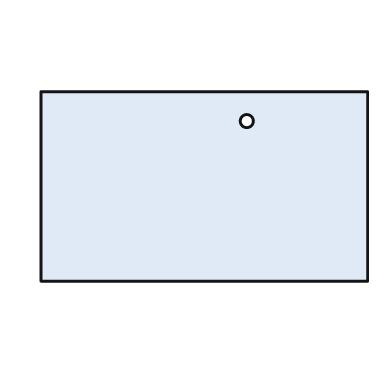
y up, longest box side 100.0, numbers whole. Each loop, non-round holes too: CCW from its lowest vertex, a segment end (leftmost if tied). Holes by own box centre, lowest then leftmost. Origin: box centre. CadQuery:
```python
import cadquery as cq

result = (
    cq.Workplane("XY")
    .moveTo(-50.0, -29.0)
    .lineTo(50.0, -29.0)
    .lineTo(50.0, 29.0)
    .lineTo(-50.0, 29.0)
    .close()
    .moveTo(13.0, 20.0)
    .circle(2.0)
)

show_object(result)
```